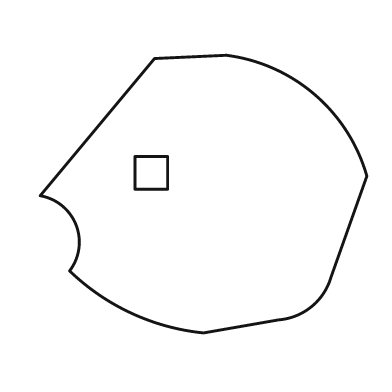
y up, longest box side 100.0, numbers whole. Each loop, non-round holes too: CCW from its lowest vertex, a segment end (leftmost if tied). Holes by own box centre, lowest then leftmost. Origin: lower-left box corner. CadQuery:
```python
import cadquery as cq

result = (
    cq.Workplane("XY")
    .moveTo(50.0, 0.0)
    .lineTo(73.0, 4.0)
    .threePointArc((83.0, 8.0), (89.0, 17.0))
    .lineTo(100.0, 48.0)
    .threePointArc((84.0, 73.0), (57.0, 85.0))
    .lineTo(35.0, 84.0)
    .lineTo(0.0, 42.0)
    .threePointArc((11.0, 33.0), (9.0, 19.0))
    .threePointArc((28.0, 6.0), (50.0, 0.0))
    .close()
    .moveTo(29.0, 44.0)
    .lineTo(39.0, 44.0)
    .lineTo(39.0, 54.0)
    .lineTo(29.0, 54.0)
    .close()
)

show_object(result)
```